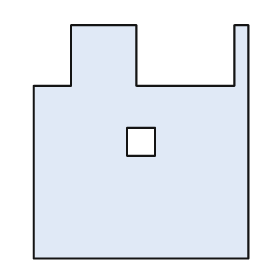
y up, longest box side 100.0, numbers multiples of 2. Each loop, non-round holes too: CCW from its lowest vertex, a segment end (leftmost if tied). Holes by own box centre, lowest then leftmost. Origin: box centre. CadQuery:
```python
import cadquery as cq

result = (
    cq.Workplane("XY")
    .moveTo(-46.0, -50.0)
    .lineTo(46.0, -50.0)
    .lineTo(46.0, 50.0)
    .lineTo(40.0, 50.0)
    .lineTo(40.0, 24.0)
    .lineTo(-2.0, 24.0)
    .lineTo(-2.0, 50.0)
    .lineTo(-30.0, 50.0)
    .lineTo(-30.0, 24.0)
    .lineTo(-46.0, 24.0)
    .close()
    .moveTo(-6.0, -6.0)
    .lineTo(6.0, -6.0)
    .lineTo(6.0, 6.0)
    .lineTo(-6.0, 6.0)
    .close()
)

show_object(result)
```